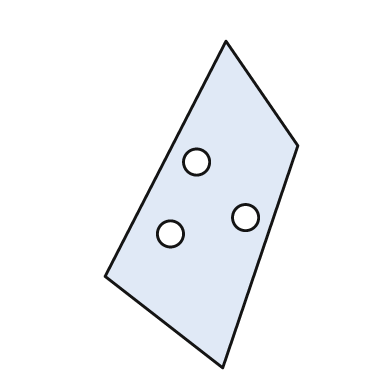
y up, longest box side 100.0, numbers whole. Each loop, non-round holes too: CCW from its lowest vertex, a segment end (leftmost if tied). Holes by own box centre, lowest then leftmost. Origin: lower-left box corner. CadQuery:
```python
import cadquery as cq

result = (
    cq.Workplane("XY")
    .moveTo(36.0, 0.0)
    .lineTo(59.0, 68.0)
    .lineTo(37.0, 100.0)
    .lineTo(0.0, 28.0)
    .close()
    .moveTo(20.0, 41.0)
    .circle(4.0)
    .moveTo(43.0, 46.0)
    .circle(4.0)
    .moveTo(28.0, 63.0)
    .circle(4.0)
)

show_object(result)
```